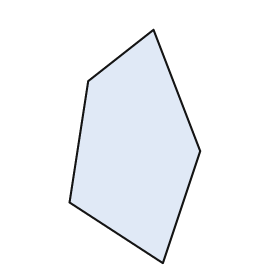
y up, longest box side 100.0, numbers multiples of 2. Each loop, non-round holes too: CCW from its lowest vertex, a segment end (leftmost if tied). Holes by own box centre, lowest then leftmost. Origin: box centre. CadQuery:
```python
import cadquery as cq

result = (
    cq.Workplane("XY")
    .moveTo(12.0, -50.0)
    .lineTo(28.0, -2.0)
    .lineTo(8.0, 50.0)
    .lineTo(-20.0, 28.0)
    .lineTo(-28.0, -24.0)
    .close()
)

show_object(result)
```